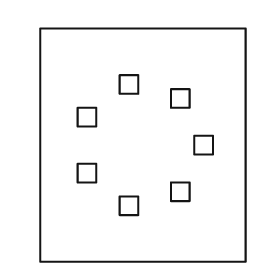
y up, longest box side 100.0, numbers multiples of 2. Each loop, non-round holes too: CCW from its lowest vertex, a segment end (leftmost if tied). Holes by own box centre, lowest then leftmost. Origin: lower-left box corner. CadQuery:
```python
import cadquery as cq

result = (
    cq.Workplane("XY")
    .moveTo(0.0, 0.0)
    .lineTo(88.0, 0.0)
    .lineTo(88.0, 100.0)
    .lineTo(0.0, 100.0)
    .close()
    .moveTo(34.0, 20.0)
    .lineTo(42.0, 20.0)
    .lineTo(42.0, 28.0)
    .lineTo(34.0, 28.0)
    .close()
    .moveTo(56.0, 26.0)
    .lineTo(64.0, 26.0)
    .lineTo(64.0, 34.0)
    .lineTo(56.0, 34.0)
    .close()
    .moveTo(16.0, 34.0)
    .lineTo(24.0, 34.0)
    .lineTo(24.0, 42.0)
    .lineTo(16.0, 42.0)
    .close()
    .moveTo(66.0, 46.0)
    .lineTo(74.0, 46.0)
    .lineTo(74.0, 54.0)
    .lineTo(66.0, 54.0)
    .close()
    .moveTo(16.0, 58.0)
    .lineTo(24.0, 58.0)
    .lineTo(24.0, 66.0)
    .lineTo(16.0, 66.0)
    .close()
    .moveTo(56.0, 66.0)
    .lineTo(64.0, 66.0)
    .lineTo(64.0, 74.0)
    .lineTo(56.0, 74.0)
    .close()
    .moveTo(34.0, 72.0)
    .lineTo(42.0, 72.0)
    .lineTo(42.0, 80.0)
    .lineTo(34.0, 80.0)
    .close()
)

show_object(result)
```